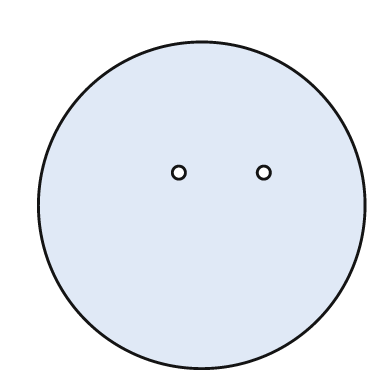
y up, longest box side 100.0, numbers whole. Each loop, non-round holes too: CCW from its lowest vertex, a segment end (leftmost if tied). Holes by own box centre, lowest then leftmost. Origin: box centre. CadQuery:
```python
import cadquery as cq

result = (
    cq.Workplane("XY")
    .moveTo(0.0, 0.0)
    .circle(50.0)
    .moveTo(-7.0, 10.0)
    .circle(2.0)
    .moveTo(19.0, 10.0)
    .circle(2.0)
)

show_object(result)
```